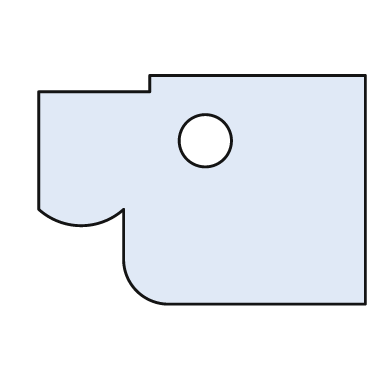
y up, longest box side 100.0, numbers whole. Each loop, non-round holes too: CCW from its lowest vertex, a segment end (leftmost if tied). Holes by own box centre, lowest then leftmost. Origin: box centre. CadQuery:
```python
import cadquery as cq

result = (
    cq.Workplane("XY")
    .moveTo(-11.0, -35.0)
    .lineTo(50.0, -35.0)
    .lineTo(50.0, 35.0)
    .lineTo(-16.0, 35.0)
    .lineTo(-16.0, 30.0)
    .lineTo(-50.0, 30.0)
    .lineTo(-50.0, -6.0)
    .threePointArc((-37.0, -11.0), (-24.0, -6.0))
    .lineTo(-24.0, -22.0)
    .threePointArc((-20.0, -31.0), (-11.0, -35.0))
    .close()
    .moveTo(1.0, 15.0)
    .circle(8.0)
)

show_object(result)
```